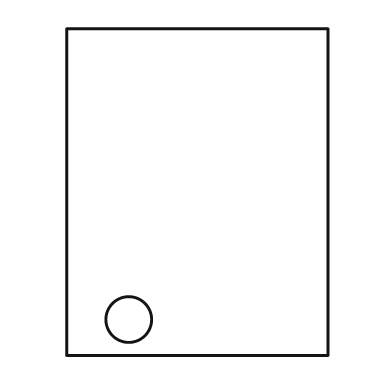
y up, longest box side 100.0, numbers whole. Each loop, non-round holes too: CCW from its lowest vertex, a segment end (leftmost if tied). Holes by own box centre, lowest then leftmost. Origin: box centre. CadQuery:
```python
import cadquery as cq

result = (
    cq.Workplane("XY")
    .moveTo(-40.0, -50.0)
    .lineTo(40.0, -50.0)
    .lineTo(40.0, 50.0)
    .lineTo(-40.0, 50.0)
    .close()
    .moveTo(-21.0, -39.0)
    .circle(7.0)
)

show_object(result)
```